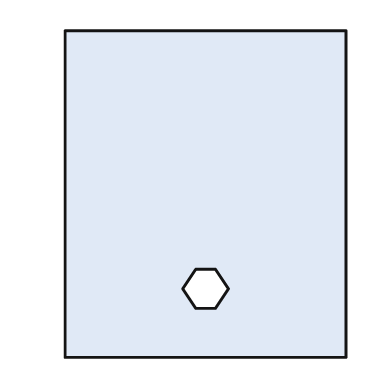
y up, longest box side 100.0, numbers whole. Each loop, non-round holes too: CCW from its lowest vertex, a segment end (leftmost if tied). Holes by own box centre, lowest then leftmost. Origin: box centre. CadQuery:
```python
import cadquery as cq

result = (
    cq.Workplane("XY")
    .moveTo(-43.0, -50.0)
    .lineTo(43.0, -50.0)
    .lineTo(43.0, 50.0)
    .lineTo(-43.0, 50.0)
    .close()
    .moveTo(-3.0, -35.0)
    .lineTo(3.0, -35.0)
    .lineTo(7.0, -29.0)
    .lineTo(3.0, -23.0)
    .lineTo(-3.0, -23.0)
    .lineTo(-7.0, -29.0)
    .close()
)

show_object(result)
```